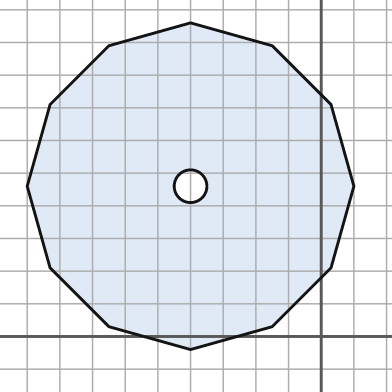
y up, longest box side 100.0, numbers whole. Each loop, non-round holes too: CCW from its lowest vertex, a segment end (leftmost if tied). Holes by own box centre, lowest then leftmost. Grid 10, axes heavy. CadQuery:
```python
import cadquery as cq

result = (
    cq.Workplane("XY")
    .moveTo(-40.0, -4.0)
    .lineTo(-15.0, 3.0)
    .lineTo(3.0, 21.0)
    .lineTo(10.0, 46.0)
    .lineTo(3.0, 71.0)
    .lineTo(-15.0, 89.0)
    .lineTo(-40.0, 96.0)
    .lineTo(-65.0, 89.0)
    .lineTo(-83.0, 71.0)
    .lineTo(-90.0, 46.0)
    .lineTo(-83.0, 21.0)
    .lineTo(-65.0, 3.0)
    .close()
    .moveTo(-40.0, 46.0)
    .circle(5.0)
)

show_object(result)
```